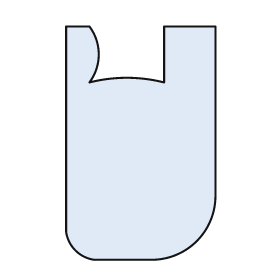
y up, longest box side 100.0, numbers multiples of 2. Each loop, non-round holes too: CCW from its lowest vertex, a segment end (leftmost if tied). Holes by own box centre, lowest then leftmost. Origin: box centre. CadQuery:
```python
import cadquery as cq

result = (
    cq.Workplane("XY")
    .moveTo(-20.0, -50.0)
    .lineTo(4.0, -50.0)
    .threePointArc((24.0, -42.0), (32.0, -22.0))
    .lineTo(32.0, 50.0)
    .lineTo(10.0, 50.0)
    .lineTo(10.0, 26.0)
    .threePointArc((-6.0, 28.0), (-22.0, 26.0))
    .threePointArc((-18.0, 38.0), (-22.0, 50.0))
    .lineTo(-32.0, 50.0)
    .lineTo(-32.0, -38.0)
    .threePointArc((-28.0, -46.0), (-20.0, -50.0))
    .close()
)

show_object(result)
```